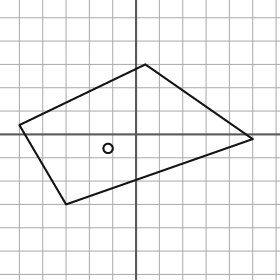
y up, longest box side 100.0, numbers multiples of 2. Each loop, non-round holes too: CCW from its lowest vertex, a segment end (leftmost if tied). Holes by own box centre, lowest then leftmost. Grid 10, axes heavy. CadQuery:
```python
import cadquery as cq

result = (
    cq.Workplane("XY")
    .moveTo(-30.0, -30.0)
    .lineTo(50.0, -2.0)
    .lineTo(4.0, 30.0)
    .lineTo(-50.0, 4.0)
    .close()
    .moveTo(-12.0, -6.0)
    .circle(2.0)
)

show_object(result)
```